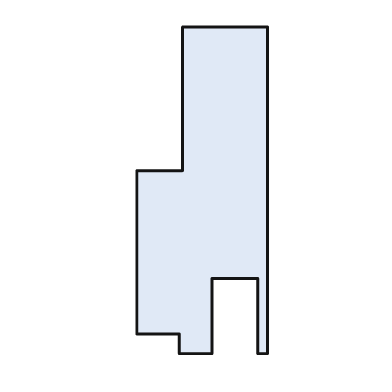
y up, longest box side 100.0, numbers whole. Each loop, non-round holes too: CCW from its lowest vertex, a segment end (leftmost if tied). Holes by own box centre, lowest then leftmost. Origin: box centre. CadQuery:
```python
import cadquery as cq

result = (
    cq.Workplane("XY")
    .moveTo(-7.0, -50.0)
    .lineTo(3.0, -50.0)
    .lineTo(3.0, -27.0)
    .lineTo(17.0, -27.0)
    .lineTo(17.0, -50.0)
    .lineTo(20.0, -50.0)
    .lineTo(20.0, 50.0)
    .lineTo(-6.0, 50.0)
    .lineTo(-6.0, 6.0)
    .lineTo(-20.0, 6.0)
    .lineTo(-20.0, -44.0)
    .lineTo(-7.0, -44.0)
    .close()
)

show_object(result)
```